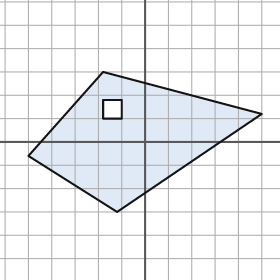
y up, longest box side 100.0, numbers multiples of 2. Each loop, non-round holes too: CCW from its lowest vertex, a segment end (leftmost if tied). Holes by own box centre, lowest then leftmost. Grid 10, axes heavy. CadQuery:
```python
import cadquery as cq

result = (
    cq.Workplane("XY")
    .moveTo(-12.0, -30.0)
    .lineTo(50.0, 12.0)
    .lineTo(-18.0, 30.0)
    .lineTo(-50.0, -6.0)
    .close()
    .moveTo(-18.0, 10.0)
    .lineTo(-10.0, 10.0)
    .lineTo(-10.0, 18.0)
    .lineTo(-18.0, 18.0)
    .close()
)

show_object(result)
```